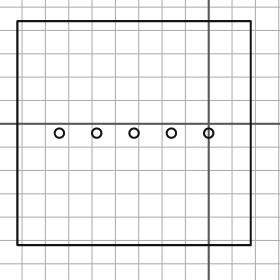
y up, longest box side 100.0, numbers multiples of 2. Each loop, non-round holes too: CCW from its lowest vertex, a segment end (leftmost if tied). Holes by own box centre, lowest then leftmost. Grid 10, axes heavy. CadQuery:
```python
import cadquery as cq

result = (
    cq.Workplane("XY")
    .moveTo(-82.0, -52.0)
    .lineTo(18.0, -52.0)
    .lineTo(18.0, 44.0)
    .lineTo(-82.0, 44.0)
    .close()
    .moveTo(-64.0, -4.0)
    .circle(2.0)
    .moveTo(-48.0, -4.0)
    .circle(2.0)
    .moveTo(-32.0, -4.0)
    .circle(2.0)
    .moveTo(-16.0, -4.0)
    .circle(2.0)
    .moveTo(0.0, -4.0)
    .circle(2.0)
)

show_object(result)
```